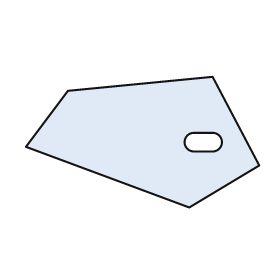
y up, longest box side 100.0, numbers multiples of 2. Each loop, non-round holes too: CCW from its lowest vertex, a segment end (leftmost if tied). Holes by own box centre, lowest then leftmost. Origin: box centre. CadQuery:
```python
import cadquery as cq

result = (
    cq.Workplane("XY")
    .moveTo(20.0, -28.0)
    .lineTo(50.0, -10.0)
    .lineTo(30.0, 28.0)
    .lineTo(-32.0, 22.0)
    .lineTo(-50.0, -2.0)
    .close()
    .moveTo(22.0, -4.0)
    .lineTo(30.0, -4.0)
    .threePointArc((34.0, 0.0), (30.0, 4.0))
    .lineTo(22.0, 4.0)
    .threePointArc((18.0, 0.0), (22.0, -4.0))
    .close()
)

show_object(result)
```